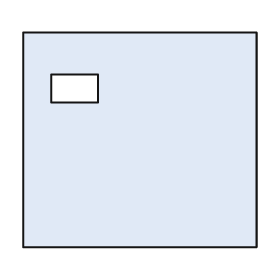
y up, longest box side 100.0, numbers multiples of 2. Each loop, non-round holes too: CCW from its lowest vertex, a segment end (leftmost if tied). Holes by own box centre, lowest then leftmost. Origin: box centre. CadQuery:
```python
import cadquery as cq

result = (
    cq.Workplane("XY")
    .moveTo(-50.0, -46.0)
    .lineTo(50.0, -46.0)
    .lineTo(50.0, 46.0)
    .lineTo(-50.0, 46.0)
    .close()
    .moveTo(-38.0, 16.0)
    .lineTo(-18.0, 16.0)
    .lineTo(-18.0, 28.0)
    .lineTo(-38.0, 28.0)
    .close()
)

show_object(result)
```